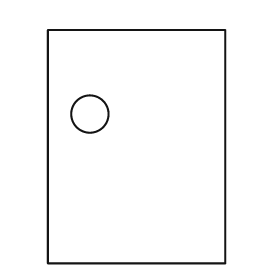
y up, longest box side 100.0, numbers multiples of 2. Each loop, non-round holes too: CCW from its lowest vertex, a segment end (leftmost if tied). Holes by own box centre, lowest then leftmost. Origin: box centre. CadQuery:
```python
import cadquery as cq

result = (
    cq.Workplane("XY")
    .moveTo(-38.0, -50.0)
    .lineTo(38.0, -50.0)
    .lineTo(38.0, 50.0)
    .lineTo(-38.0, 50.0)
    .close()
    .moveTo(-20.0, 14.0)
    .circle(8.0)
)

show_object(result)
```